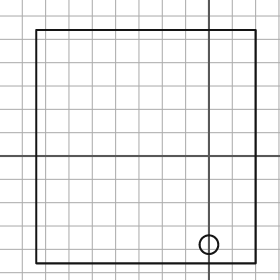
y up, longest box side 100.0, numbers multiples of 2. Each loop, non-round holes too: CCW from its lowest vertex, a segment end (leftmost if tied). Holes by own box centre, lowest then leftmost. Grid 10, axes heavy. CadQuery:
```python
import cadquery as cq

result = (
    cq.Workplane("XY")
    .moveTo(-74.0, -46.0)
    .lineTo(20.0, -46.0)
    .lineTo(20.0, 54.0)
    .lineTo(-74.0, 54.0)
    .close()
    .moveTo(0.0, -38.0)
    .circle(4.0)
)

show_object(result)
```